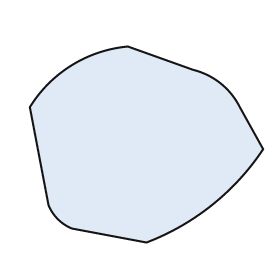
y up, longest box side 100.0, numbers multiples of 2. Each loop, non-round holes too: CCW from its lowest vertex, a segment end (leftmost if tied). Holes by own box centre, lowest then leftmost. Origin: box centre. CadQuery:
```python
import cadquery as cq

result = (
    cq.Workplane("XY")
    .moveTo(0.0, -42.0)
    .threePointArc((28.0, -26.0), (50.0, -2.0))
    .lineTo(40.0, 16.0)
    .threePointArc((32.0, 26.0), (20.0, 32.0))
    .lineTo(-8.0, 42.0)
    .threePointArc((-32.0, 34.0), (-50.0, 16.0))
    .lineTo(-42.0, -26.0)
    .threePointArc((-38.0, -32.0), (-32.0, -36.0))
    .close()
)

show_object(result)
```